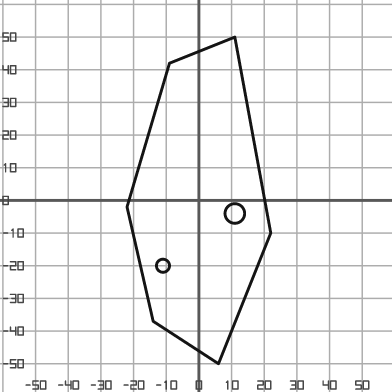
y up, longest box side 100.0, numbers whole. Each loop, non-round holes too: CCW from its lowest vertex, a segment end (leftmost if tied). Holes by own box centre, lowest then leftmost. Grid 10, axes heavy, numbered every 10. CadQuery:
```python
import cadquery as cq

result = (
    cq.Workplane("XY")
    .moveTo(6.0, -50.0)
    .lineTo(22.0, -10.0)
    .lineTo(11.0, 50.0)
    .lineTo(-9.0, 42.0)
    .lineTo(-22.0, -2.0)
    .lineTo(-14.0, -37.0)
    .close()
    .moveTo(-11.0, -20.0)
    .circle(2.0)
    .moveTo(11.0, -4.0)
    .circle(3.0)
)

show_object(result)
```